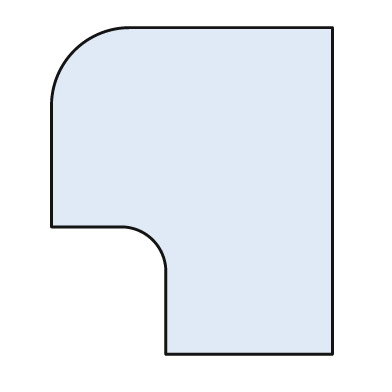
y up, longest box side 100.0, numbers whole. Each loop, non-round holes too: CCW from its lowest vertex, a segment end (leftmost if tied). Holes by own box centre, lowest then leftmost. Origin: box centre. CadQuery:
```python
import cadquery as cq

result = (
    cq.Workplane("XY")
    .moveTo(-8.0, -50.0)
    .lineTo(43.0, -50.0)
    .lineTo(43.0, 50.0)
    .lineTo(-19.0, 50.0)
    .threePointArc((-36.0, 43.0), (-43.0, 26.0))
    .lineTo(-43.0, -11.0)
    .lineTo(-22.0, -11.0)
    .threePointArc((-12.0, -15.0), (-8.0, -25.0))
    .close()
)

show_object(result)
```